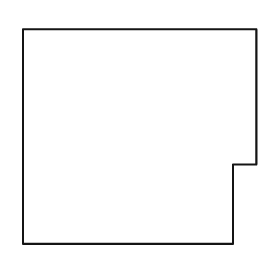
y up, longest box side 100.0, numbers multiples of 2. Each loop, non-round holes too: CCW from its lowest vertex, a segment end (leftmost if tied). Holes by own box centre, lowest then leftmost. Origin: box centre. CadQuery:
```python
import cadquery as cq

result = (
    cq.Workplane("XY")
    .moveTo(-50.0, -46.0)
    .lineTo(40.0, -46.0)
    .lineTo(40.0, -12.0)
    .lineTo(50.0, -12.0)
    .lineTo(50.0, 46.0)
    .lineTo(-50.0, 46.0)
    .close()
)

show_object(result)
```